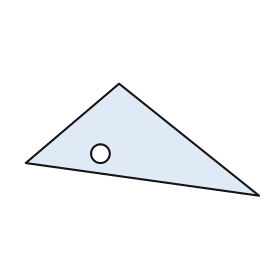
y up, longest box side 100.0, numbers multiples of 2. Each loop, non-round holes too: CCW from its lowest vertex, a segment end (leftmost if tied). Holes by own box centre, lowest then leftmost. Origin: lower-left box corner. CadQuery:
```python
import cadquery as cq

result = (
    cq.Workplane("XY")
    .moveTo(100.0, 0.0)
    .lineTo(40.0, 48.0)
    .lineTo(0.0, 14.0)
    .close()
    .moveTo(32.0, 18.0)
    .circle(4.0)
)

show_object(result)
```